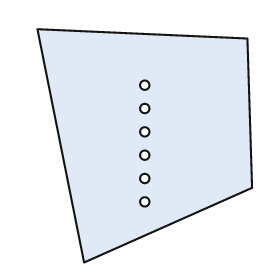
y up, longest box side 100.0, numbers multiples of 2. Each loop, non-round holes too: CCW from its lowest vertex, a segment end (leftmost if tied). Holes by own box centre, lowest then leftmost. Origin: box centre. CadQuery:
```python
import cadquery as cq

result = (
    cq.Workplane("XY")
    .moveTo(-26.0, -50.0)
    .lineTo(46.0, -18.0)
    .lineTo(44.0, 46.0)
    .lineTo(-46.0, 50.0)
    .close()
    .moveTo(0.0, -24.0)
    .circle(2.0)
    .moveTo(0.0, -14.0)
    .circle(2.0)
    .moveTo(0.0, -4.0)
    .circle(2.0)
    .moveTo(0.0, 6.0)
    .circle(2.0)
    .moveTo(0.0, 16.0)
    .circle(2.0)
    .moveTo(0.0, 26.0)
    .circle(2.0)
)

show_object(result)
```